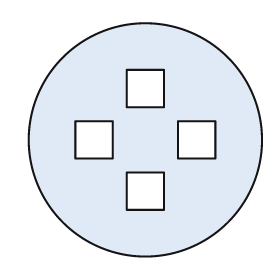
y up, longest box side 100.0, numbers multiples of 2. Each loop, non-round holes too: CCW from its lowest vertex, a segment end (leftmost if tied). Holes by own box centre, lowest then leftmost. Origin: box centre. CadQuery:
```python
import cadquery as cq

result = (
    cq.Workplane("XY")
    .moveTo(0.0, 0.0)
    .circle(50.0)
    .moveTo(-8.0, -30.0)
    .lineTo(8.0, -30.0)
    .lineTo(8.0, -14.0)
    .lineTo(-8.0, -14.0)
    .close()
    .moveTo(-30.0, -8.0)
    .lineTo(-14.0, -8.0)
    .lineTo(-14.0, 8.0)
    .lineTo(-30.0, 8.0)
    .close()
    .moveTo(14.0, -8.0)
    .lineTo(30.0, -8.0)
    .lineTo(30.0, 8.0)
    .lineTo(14.0, 8.0)
    .close()
    .moveTo(-8.0, 14.0)
    .lineTo(8.0, 14.0)
    .lineTo(8.0, 30.0)
    .lineTo(-8.0, 30.0)
    .close()
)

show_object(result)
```